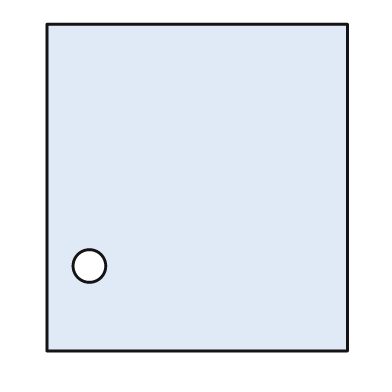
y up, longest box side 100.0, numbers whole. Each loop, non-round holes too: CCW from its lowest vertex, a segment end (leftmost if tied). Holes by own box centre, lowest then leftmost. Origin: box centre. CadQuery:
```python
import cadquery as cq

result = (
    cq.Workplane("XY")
    .moveTo(-46.0, -50.0)
    .lineTo(46.0, -50.0)
    .lineTo(46.0, 50.0)
    .lineTo(-46.0, 50.0)
    .close()
    .moveTo(-33.0, -24.0)
    .circle(5.0)
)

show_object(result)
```